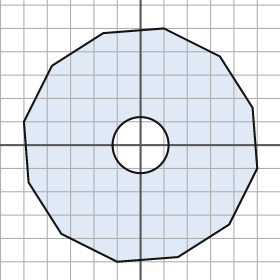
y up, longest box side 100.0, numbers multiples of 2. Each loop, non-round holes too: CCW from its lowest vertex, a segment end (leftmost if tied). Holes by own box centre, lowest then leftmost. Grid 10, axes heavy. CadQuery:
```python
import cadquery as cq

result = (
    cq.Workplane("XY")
    .moveTo(-10.0, -50.0)
    .lineTo(16.0, -48.0)
    .lineTo(38.0, -34.0)
    .lineTo(50.0, -10.0)
    .lineTo(48.0, 16.0)
    .lineTo(34.0, 38.0)
    .lineTo(10.0, 50.0)
    .lineTo(-16.0, 48.0)
    .lineTo(-38.0, 34.0)
    .lineTo(-50.0, 10.0)
    .lineTo(-48.0, -16.0)
    .lineTo(-34.0, -38.0)
    .close()
    .moveTo(0.0, 0.0)
    .circle(12.0)
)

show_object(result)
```